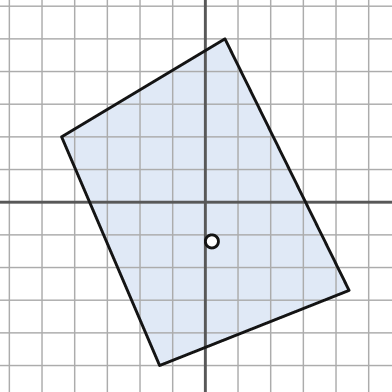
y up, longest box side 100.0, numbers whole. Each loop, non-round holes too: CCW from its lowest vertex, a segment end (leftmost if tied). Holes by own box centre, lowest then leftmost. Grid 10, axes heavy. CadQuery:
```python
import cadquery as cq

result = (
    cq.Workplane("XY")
    .moveTo(-14.0, -50.0)
    .lineTo(44.0, -27.0)
    .lineTo(6.0, 50.0)
    .lineTo(-44.0, 20.0)
    .close()
    .moveTo(2.0, -12.0)
    .circle(2.0)
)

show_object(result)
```